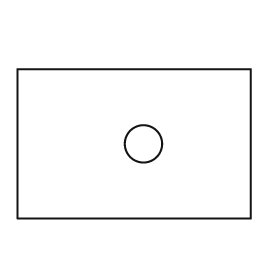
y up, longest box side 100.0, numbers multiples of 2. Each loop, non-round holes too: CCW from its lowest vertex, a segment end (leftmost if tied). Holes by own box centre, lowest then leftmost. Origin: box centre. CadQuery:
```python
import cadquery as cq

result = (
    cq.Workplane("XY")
    .moveTo(-50.0, -32.0)
    .lineTo(50.0, -32.0)
    .lineTo(50.0, 32.0)
    .lineTo(-50.0, 32.0)
    .close()
    .moveTo(4.0, 0.0)
    .circle(8.0)
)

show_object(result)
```